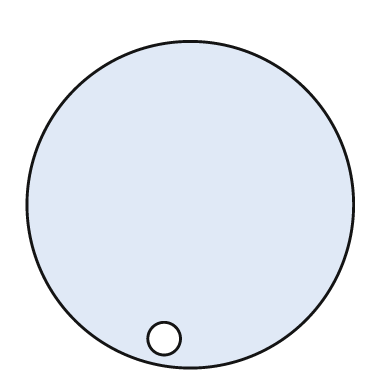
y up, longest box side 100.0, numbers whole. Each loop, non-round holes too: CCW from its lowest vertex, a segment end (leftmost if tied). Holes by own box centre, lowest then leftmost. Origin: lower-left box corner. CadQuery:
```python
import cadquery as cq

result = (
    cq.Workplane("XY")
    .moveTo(50.0, 50.0)
    .circle(50.0)
    .moveTo(42.0, 9.0)
    .circle(5.0)
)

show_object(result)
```